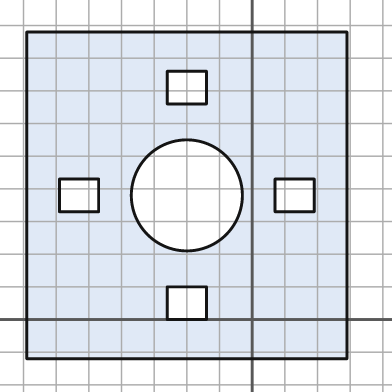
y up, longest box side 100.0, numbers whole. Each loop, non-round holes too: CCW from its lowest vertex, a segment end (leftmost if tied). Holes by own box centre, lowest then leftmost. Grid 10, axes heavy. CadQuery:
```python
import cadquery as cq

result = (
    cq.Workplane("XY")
    .moveTo(-69.0, -12.0)
    .lineTo(29.0, -12.0)
    .lineTo(29.0, 88.0)
    .lineTo(-69.0, 88.0)
    .close()
    .moveTo(-26.0, 0.0)
    .lineTo(-14.0, 0.0)
    .lineTo(-14.0, 10.0)
    .lineTo(-26.0, 10.0)
    .close()
    .moveTo(-59.0, 33.0)
    .lineTo(-47.0, 33.0)
    .lineTo(-47.0, 43.0)
    .lineTo(-59.0, 43.0)
    .close()
    .moveTo(-20.0, 38.0)
    .circle(17.0)
    .moveTo(7.0, 33.0)
    .lineTo(19.0, 33.0)
    .lineTo(19.0, 43.0)
    .lineTo(7.0, 43.0)
    .close()
    .moveTo(-26.0, 66.0)
    .lineTo(-14.0, 66.0)
    .lineTo(-14.0, 76.0)
    .lineTo(-26.0, 76.0)
    .close()
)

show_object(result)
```